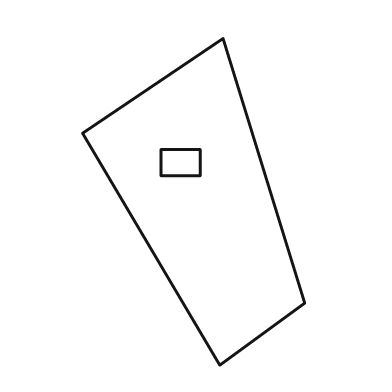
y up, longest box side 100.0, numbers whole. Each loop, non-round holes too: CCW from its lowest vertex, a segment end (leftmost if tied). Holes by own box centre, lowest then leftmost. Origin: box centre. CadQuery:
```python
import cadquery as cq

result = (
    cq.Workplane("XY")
    .moveTo(8.0, -50.0)
    .lineTo(34.0, -31.0)
    .lineTo(9.0, 50.0)
    .lineTo(-34.0, 21.0)
    .close()
    .moveTo(-10.0, 8.0)
    .lineTo(2.0, 8.0)
    .lineTo(2.0, 16.0)
    .lineTo(-10.0, 16.0)
    .close()
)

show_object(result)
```